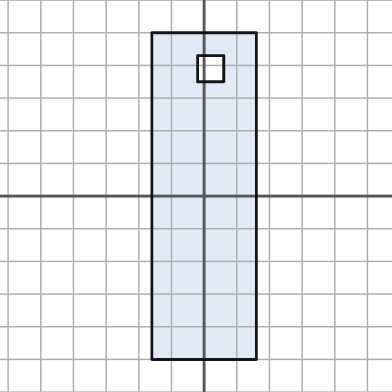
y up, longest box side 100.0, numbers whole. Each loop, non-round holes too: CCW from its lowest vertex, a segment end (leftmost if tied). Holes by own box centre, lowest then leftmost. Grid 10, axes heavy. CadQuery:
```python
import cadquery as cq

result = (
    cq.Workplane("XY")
    .moveTo(-16.0, -50.0)
    .lineTo(16.0, -50.0)
    .lineTo(16.0, 50.0)
    .lineTo(-16.0, 50.0)
    .close()
    .moveTo(-2.0, 35.0)
    .lineTo(6.0, 35.0)
    .lineTo(6.0, 43.0)
    .lineTo(-2.0, 43.0)
    .close()
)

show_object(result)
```